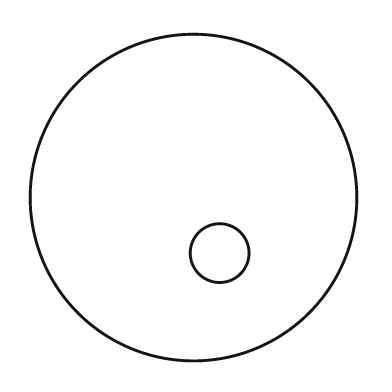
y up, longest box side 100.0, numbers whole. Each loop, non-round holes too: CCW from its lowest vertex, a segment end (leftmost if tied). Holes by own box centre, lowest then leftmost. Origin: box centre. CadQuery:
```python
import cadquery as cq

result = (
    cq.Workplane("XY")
    .moveTo(0.0, 0.0)
    .circle(50.0)
    .moveTo(8.0, -17.0)
    .circle(9.0)
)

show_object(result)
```